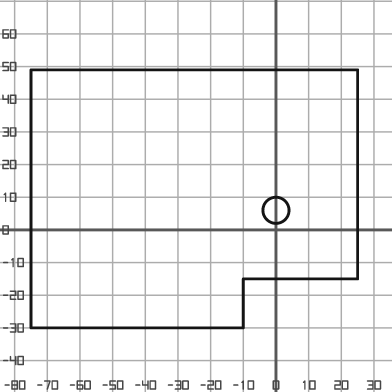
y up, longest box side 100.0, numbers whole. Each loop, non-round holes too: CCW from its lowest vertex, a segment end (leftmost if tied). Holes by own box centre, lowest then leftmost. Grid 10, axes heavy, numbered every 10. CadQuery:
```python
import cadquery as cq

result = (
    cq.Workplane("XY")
    .moveTo(-75.0, -30.0)
    .lineTo(-10.0, -30.0)
    .lineTo(-10.0, -15.0)
    .lineTo(25.0, -15.0)
    .lineTo(25.0, 49.0)
    .lineTo(-75.0, 49.0)
    .close()
    .moveTo(0.0, 6.0)
    .circle(4.0)
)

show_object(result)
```